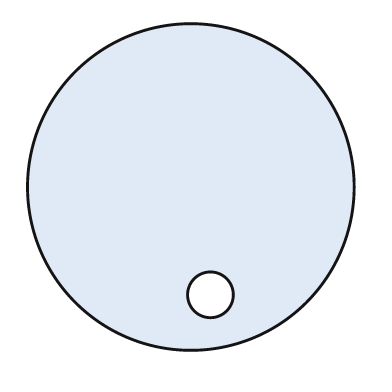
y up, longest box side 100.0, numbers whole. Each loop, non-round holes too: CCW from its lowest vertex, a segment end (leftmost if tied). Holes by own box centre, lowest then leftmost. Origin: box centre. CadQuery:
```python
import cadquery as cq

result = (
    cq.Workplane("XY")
    .moveTo(0.0, 0.0)
    .circle(50.0)
    .moveTo(6.0, -33.0)
    .circle(7.0)
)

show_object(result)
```